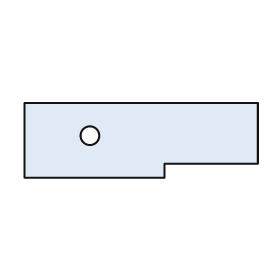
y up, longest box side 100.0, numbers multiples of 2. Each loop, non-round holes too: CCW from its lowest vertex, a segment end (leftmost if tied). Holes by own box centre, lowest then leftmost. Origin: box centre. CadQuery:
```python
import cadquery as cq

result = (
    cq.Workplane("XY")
    .moveTo(-50.0, -16.0)
    .lineTo(10.0, -16.0)
    .lineTo(10.0, -10.0)
    .lineTo(50.0, -10.0)
    .lineTo(50.0, 16.0)
    .lineTo(-50.0, 16.0)
    .close()
    .moveTo(-22.0, 2.0)
    .circle(4.0)
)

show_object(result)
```